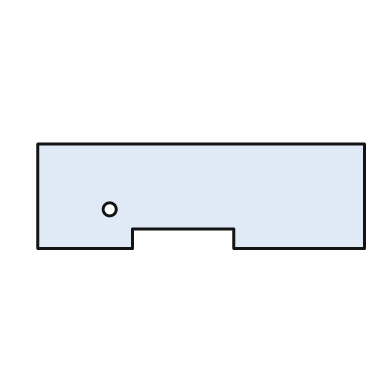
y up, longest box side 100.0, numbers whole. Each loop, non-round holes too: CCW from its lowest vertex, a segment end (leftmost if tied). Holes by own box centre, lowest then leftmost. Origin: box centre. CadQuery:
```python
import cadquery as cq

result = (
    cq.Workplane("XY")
    .moveTo(-50.0, -16.0)
    .lineTo(-21.0, -16.0)
    .lineTo(-21.0, -10.0)
    .lineTo(10.0, -10.0)
    .lineTo(10.0, -16.0)
    .lineTo(50.0, -16.0)
    .lineTo(50.0, 16.0)
    .lineTo(-50.0, 16.0)
    .close()
    .moveTo(-28.0, -4.0)
    .circle(2.0)
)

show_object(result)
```